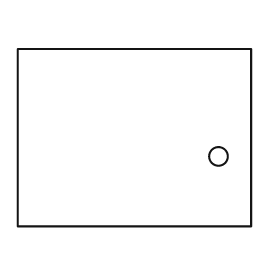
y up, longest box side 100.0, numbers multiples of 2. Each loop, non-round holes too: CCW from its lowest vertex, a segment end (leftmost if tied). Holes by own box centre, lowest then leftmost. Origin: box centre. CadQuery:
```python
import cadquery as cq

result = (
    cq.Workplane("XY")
    .moveTo(-50.0, -38.0)
    .lineTo(50.0, -38.0)
    .lineTo(50.0, 38.0)
    .lineTo(-50.0, 38.0)
    .close()
    .moveTo(36.0, -8.0)
    .circle(4.0)
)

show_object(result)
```